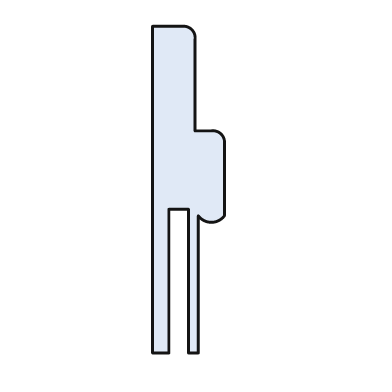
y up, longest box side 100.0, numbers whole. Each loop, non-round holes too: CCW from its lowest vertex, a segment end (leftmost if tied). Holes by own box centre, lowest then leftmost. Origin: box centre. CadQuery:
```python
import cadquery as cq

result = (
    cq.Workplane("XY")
    .moveTo(-11.0, -50.0)
    .lineTo(-6.0, -50.0)
    .lineTo(-6.0, -6.0)
    .lineTo(0.0, -6.0)
    .lineTo(0.0, -50.0)
    .lineTo(3.0, -50.0)
    .lineTo(3.0, -8.0)
    .threePointArc((7.0, -10.0), (11.0, -8.0))
    .lineTo(11.0, 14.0)
    .threePointArc((10.0, 17.0), (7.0, 18.0))
    .lineTo(2.0, 18.0)
    .lineTo(2.0, 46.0)
    .threePointArc((1.0, 49.0), (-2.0, 50.0))
    .lineTo(-11.0, 50.0)
    .close()
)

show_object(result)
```